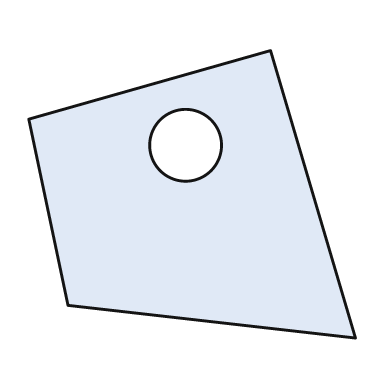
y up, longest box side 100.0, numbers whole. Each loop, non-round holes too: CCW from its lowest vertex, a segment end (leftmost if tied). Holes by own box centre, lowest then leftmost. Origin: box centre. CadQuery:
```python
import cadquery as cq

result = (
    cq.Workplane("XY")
    .moveTo(50.0, -44.0)
    .lineTo(24.0, 44.0)
    .lineTo(-50.0, 23.0)
    .lineTo(-38.0, -34.0)
    .close()
    .moveTo(-2.0, 15.0)
    .circle(11.0)
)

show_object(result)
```